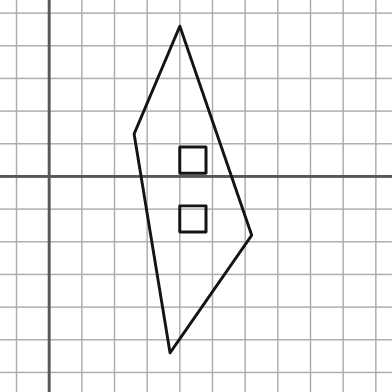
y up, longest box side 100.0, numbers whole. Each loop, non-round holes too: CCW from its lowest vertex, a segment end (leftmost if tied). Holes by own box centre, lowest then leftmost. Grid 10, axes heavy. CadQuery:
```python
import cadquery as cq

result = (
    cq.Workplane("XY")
    .moveTo(37.0, -54.0)
    .lineTo(62.0, -18.0)
    .lineTo(40.0, 46.0)
    .lineTo(26.0, 13.0)
    .close()
    .moveTo(40.0, -17.0)
    .lineTo(48.0, -17.0)
    .lineTo(48.0, -9.0)
    .lineTo(40.0, -9.0)
    .close()
    .moveTo(40.0, 1.0)
    .lineTo(48.0, 1.0)
    .lineTo(48.0, 9.0)
    .lineTo(40.0, 9.0)
    .close()
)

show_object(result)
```